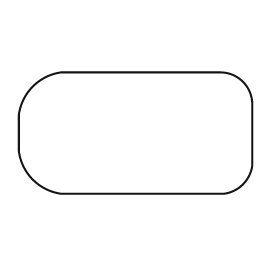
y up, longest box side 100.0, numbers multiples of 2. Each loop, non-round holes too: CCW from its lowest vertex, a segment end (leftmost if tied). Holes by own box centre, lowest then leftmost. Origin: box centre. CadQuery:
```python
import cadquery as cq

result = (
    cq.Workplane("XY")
    .moveTo(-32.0, -26.0)
    .lineTo(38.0, -26.0)
    .threePointArc((46.0, -22.0), (50.0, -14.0))
    .lineTo(50.0, 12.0)
    .threePointArc((46.0, 22.0), (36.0, 26.0))
    .lineTo(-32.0, 26.0)
    .threePointArc((-44.0, 20.0), (-50.0, 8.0))
    .lineTo(-50.0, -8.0)
    .threePointArc((-44.0, -20.0), (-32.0, -26.0))
    .close()
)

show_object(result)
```